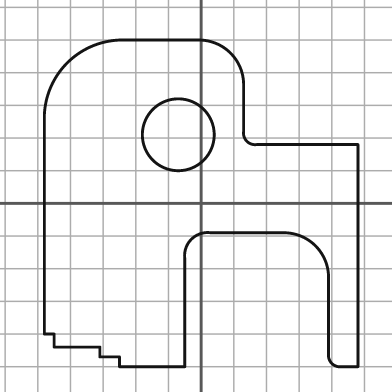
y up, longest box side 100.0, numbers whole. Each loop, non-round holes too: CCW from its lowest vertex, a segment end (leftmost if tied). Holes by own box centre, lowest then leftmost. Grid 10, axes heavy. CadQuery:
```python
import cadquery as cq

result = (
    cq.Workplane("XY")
    .moveTo(-25.0, -50.0)
    .lineTo(-5.0, -50.0)
    .lineTo(-5.0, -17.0)
    .threePointArc((-3.0, -11.0), (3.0, -9.0))
    .lineTo(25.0, -9.0)
    .threePointArc((35.0, -13.0), (39.0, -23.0))
    .lineTo(39.0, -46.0)
    .threePointArc((40.0, -49.0), (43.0, -50.0))
    .lineTo(48.0, -50.0)
    .lineTo(48.0, 18.0)
    .lineTo(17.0, 18.0)
    .threePointArc((14.0, 19.0), (13.0, 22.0))
    .lineTo(13.0, 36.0)
    .threePointArc((9.0, 46.0), (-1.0, 50.0))
    .lineTo(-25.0, 50.0)
    .threePointArc((-41.0, 43.0), (-48.0, 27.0))
    .lineTo(-48.0, -40.0)
    .lineTo(-45.0, -40.0)
    .lineTo(-45.0, -44.0)
    .lineTo(-31.0, -44.0)
    .lineTo(-31.0, -47.0)
    .lineTo(-25.0, -47.0)
    .close()
    .moveTo(-7.0, 21.0)
    .circle(11.0)
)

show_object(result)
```